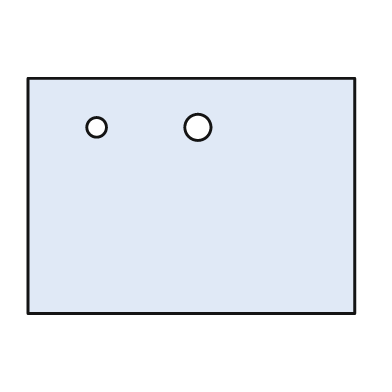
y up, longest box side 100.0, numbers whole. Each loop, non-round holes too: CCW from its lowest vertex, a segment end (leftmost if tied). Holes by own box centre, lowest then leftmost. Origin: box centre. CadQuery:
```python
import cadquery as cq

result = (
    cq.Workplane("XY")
    .moveTo(-50.0, -36.0)
    .lineTo(50.0, -36.0)
    .lineTo(50.0, 36.0)
    .lineTo(-50.0, 36.0)
    .close()
    .moveTo(-29.0, 21.0)
    .circle(3.0)
    .moveTo(2.0, 21.0)
    .circle(4.0)
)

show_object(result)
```